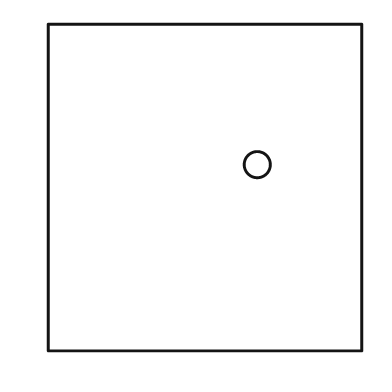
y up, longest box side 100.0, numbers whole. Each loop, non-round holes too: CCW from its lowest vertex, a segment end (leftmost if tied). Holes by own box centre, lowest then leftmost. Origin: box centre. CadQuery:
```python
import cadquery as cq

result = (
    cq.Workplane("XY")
    .moveTo(-48.0, -50.0)
    .lineTo(48.0, -50.0)
    .lineTo(48.0, 50.0)
    .lineTo(-48.0, 50.0)
    .close()
    .moveTo(16.0, 7.0)
    .circle(4.0)
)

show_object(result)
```